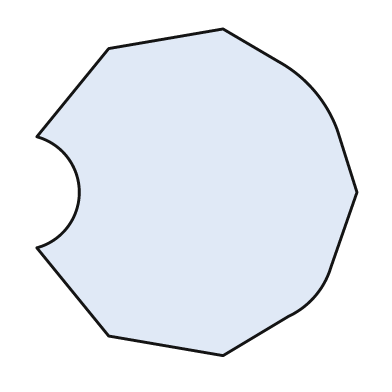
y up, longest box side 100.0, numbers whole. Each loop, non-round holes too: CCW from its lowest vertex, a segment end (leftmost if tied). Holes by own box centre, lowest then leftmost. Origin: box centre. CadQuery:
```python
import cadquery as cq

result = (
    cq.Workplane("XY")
    .moveTo(8.0, -50.0)
    .lineTo(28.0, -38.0)
    .threePointArc((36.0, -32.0), (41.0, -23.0))
    .lineTo(49.0, 0.0)
    .lineTo(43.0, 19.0)
    .threePointArc((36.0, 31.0), (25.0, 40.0))
    .lineTo(8.0, 50.0)
    .lineTo(-27.0, 44.0)
    .lineTo(-49.0, 17.0)
    .threePointArc((-36.0, 0.0), (-49.0, -17.0))
    .lineTo(-27.0, -44.0)
    .close()
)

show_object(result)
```